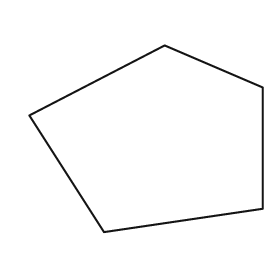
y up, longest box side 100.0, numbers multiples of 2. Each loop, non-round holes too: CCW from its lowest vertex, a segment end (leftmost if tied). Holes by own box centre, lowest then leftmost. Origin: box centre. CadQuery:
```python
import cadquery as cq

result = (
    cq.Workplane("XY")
    .moveTo(-18.0, -40.0)
    .lineTo(50.0, -30.0)
    .lineTo(50.0, 22.0)
    .lineTo(8.0, 40.0)
    .lineTo(-50.0, 10.0)
    .close()
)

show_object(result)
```